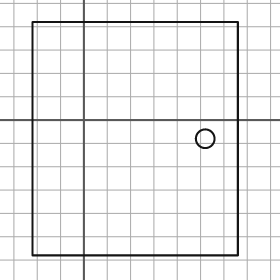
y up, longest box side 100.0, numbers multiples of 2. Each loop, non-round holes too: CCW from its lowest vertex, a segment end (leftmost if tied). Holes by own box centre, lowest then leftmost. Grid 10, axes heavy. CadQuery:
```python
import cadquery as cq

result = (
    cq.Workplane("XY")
    .moveTo(-22.0, -58.0)
    .lineTo(66.0, -58.0)
    .lineTo(66.0, 42.0)
    .lineTo(-22.0, 42.0)
    .close()
    .moveTo(52.0, -8.0)
    .circle(4.0)
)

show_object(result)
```